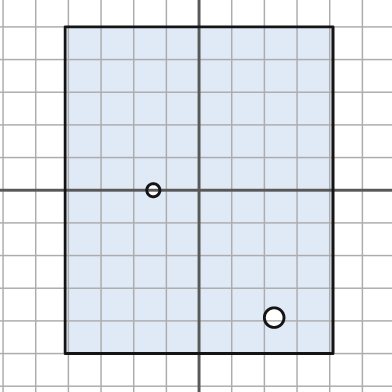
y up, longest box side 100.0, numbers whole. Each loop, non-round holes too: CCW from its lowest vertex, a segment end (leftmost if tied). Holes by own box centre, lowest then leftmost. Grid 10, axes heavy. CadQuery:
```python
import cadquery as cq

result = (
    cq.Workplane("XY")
    .moveTo(-41.0, -50.0)
    .lineTo(41.0, -50.0)
    .lineTo(41.0, 50.0)
    .lineTo(-41.0, 50.0)
    .close()
    .moveTo(23.0, -39.0)
    .circle(3.0)
    .moveTo(-14.0, 0.0)
    .circle(2.0)
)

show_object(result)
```